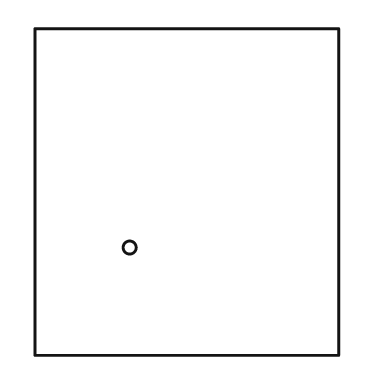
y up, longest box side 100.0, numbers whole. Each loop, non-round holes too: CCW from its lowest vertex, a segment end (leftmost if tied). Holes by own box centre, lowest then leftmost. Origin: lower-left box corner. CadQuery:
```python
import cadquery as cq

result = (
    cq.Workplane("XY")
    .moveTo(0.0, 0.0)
    .lineTo(93.0, 0.0)
    .lineTo(93.0, 100.0)
    .lineTo(0.0, 100.0)
    .close()
    .moveTo(29.0, 33.0)
    .circle(2.0)
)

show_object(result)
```